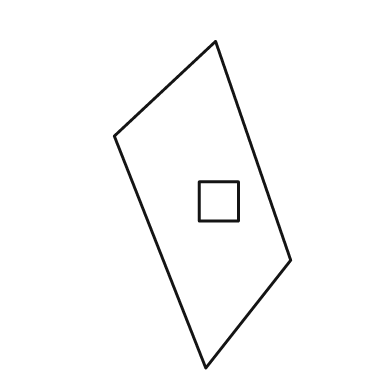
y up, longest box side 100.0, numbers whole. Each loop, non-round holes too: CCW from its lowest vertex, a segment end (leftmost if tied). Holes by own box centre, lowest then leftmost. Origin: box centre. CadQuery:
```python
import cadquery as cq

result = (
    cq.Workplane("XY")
    .moveTo(1.0, -50.0)
    .lineTo(27.0, -17.0)
    .lineTo(4.0, 50.0)
    .lineTo(-27.0, 21.0)
    .close()
    .moveTo(-1.0, -5.0)
    .lineTo(11.0, -5.0)
    .lineTo(11.0, 7.0)
    .lineTo(-1.0, 7.0)
    .close()
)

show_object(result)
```